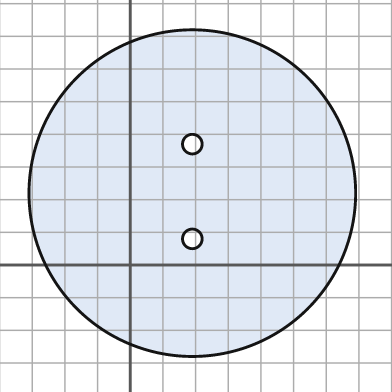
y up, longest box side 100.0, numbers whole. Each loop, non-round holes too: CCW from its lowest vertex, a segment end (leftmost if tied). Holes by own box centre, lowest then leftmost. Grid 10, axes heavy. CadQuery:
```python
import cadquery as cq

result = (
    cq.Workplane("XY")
    .moveTo(19.0, 22.0)
    .circle(50.0)
    .moveTo(19.0, 8.0)
    .circle(3.0)
    .moveTo(19.0, 37.0)
    .circle(3.0)
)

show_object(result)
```